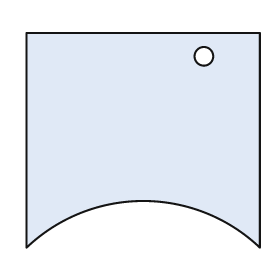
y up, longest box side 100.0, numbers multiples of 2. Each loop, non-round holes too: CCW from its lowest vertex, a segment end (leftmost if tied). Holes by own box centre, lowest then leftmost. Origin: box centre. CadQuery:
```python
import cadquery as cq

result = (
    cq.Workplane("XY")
    .moveTo(-50.0, -46.0)
    .threePointArc((0.0, -26.0), (50.0, -46.0))
    .lineTo(50.0, 46.0)
    .lineTo(-50.0, 46.0)
    .close()
    .moveTo(26.0, 36.0)
    .circle(4.0)
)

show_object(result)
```